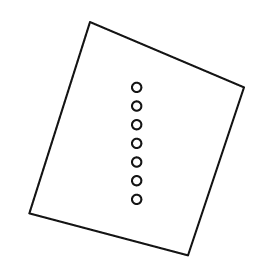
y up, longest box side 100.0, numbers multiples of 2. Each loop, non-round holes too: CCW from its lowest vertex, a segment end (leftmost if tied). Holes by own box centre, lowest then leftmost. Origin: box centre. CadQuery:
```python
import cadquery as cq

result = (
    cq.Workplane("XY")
    .moveTo(22.0, -50.0)
    .lineTo(46.0, 22.0)
    .lineTo(-20.0, 50.0)
    .lineTo(-46.0, -32.0)
    .close()
    .moveTo(0.0, -26.0)
    .circle(2.0)
    .moveTo(0.0, -18.0)
    .circle(2.0)
    .moveTo(0.0, -10.0)
    .circle(2.0)
    .moveTo(0.0, -2.0)
    .circle(2.0)
    .moveTo(0.0, 6.0)
    .circle(2.0)
    .moveTo(0.0, 14.0)
    .circle(2.0)
    .moveTo(0.0, 22.0)
    .circle(2.0)
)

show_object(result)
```